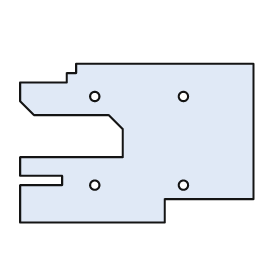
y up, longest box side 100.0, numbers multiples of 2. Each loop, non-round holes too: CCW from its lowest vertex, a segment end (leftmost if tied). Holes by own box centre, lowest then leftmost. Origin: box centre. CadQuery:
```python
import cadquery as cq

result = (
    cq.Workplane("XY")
    .moveTo(-50.0, -34.0)
    .lineTo(12.0, -34.0)
    .lineTo(12.0, -24.0)
    .lineTo(50.0, -24.0)
    .lineTo(50.0, 34.0)
    .lineTo(-26.0, 34.0)
    .lineTo(-26.0, 30.0)
    .lineTo(-30.0, 30.0)
    .lineTo(-30.0, 26.0)
    .lineTo(-50.0, 26.0)
    .lineTo(-50.0, 18.0)
    .lineTo(-44.0, 12.0)
    .lineTo(-12.0, 12.0)
    .lineTo(-6.0, 6.0)
    .lineTo(-6.0, -6.0)
    .lineTo(-50.0, -6.0)
    .lineTo(-50.0, -14.0)
    .lineTo(-32.0, -14.0)
    .lineTo(-32.0, -18.0)
    .lineTo(-50.0, -18.0)
    .close()
    .moveTo(-18.0, -18.0)
    .circle(2.0)
    .moveTo(20.0, -18.0)
    .circle(2.0)
    .moveTo(-18.0, 20.0)
    .circle(2.0)
    .moveTo(20.0, 20.0)
    .circle(2.0)
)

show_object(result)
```